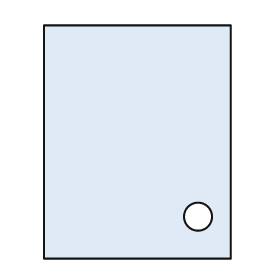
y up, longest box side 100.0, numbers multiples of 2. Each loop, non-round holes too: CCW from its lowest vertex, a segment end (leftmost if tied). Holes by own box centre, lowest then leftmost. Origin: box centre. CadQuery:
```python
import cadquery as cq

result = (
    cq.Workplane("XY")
    .moveTo(-40.0, -50.0)
    .lineTo(40.0, -50.0)
    .lineTo(40.0, 50.0)
    .lineTo(-40.0, 50.0)
    .close()
    .moveTo(26.0, -32.0)
    .circle(6.0)
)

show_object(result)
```